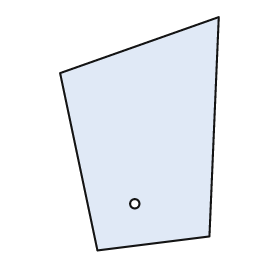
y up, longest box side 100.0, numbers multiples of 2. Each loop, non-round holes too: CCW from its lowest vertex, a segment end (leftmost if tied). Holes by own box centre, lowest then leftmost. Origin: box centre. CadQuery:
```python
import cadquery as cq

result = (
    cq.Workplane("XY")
    .moveTo(-18.0, -50.0)
    .lineTo(30.0, -44.0)
    .lineTo(34.0, 50.0)
    .lineTo(-34.0, 26.0)
    .close()
    .moveTo(-2.0, -30.0)
    .circle(2.0)
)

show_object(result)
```